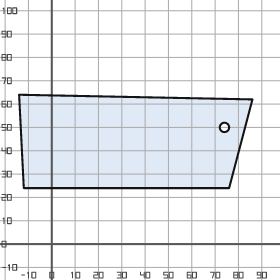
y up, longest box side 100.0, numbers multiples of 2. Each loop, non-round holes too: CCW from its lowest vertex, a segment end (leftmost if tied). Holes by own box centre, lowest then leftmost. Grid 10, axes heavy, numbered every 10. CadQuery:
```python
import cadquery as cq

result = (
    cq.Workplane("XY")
    .moveTo(-12.0, 24.0)
    .lineTo(76.0, 24.0)
    .lineTo(86.0, 62.0)
    .lineTo(-14.0, 64.0)
    .close()
    .moveTo(74.0, 50.0)
    .circle(2.0)
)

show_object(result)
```